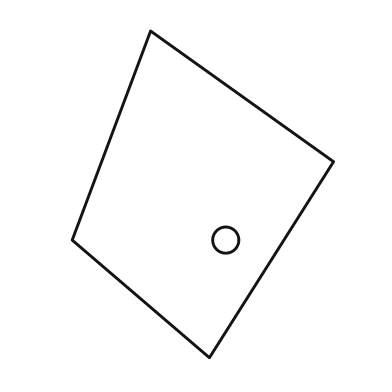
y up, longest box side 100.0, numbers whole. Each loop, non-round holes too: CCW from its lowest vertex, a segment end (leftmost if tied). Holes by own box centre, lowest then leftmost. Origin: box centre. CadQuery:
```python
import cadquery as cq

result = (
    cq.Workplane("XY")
    .moveTo(2.0, -50.0)
    .lineTo(40.0, 10.0)
    .lineTo(-16.0, 50.0)
    .lineTo(-40.0, -14.0)
    .close()
    .moveTo(7.0, -14.0)
    .circle(4.0)
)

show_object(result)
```